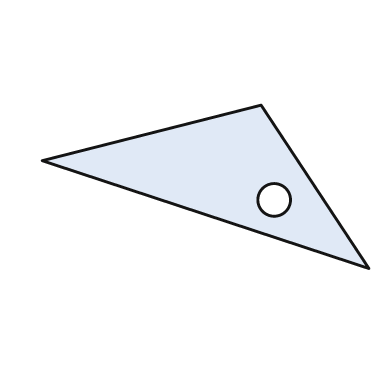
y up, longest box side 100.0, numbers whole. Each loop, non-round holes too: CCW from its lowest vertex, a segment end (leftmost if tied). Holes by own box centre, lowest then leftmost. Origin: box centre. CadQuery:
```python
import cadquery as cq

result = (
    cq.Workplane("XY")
    .moveTo(50.0, -25.0)
    .lineTo(17.0, 25.0)
    .lineTo(-50.0, 8.0)
    .close()
    .moveTo(21.0, -4.0)
    .circle(5.0)
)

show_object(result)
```